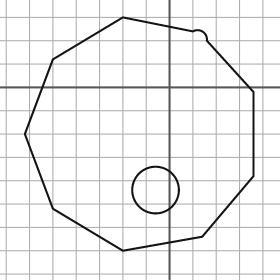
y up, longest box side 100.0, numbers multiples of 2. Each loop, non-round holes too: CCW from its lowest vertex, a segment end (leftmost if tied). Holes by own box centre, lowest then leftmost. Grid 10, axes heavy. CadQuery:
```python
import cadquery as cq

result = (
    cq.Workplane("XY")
    .moveTo(-20.0, -70.0)
    .lineTo(14.0, -64.0)
    .lineTo(36.0, -38.0)
    .lineTo(36.0, -2.0)
    .lineTo(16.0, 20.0)
    .threePointArc((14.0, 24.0), (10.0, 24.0))
    .lineTo(-20.0, 30.0)
    .lineTo(-50.0, 12.0)
    .lineTo(-62.0, -20.0)
    .lineTo(-50.0, -52.0)
    .close()
    .moveTo(-6.0, -44.0)
    .circle(10.0)
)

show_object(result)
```